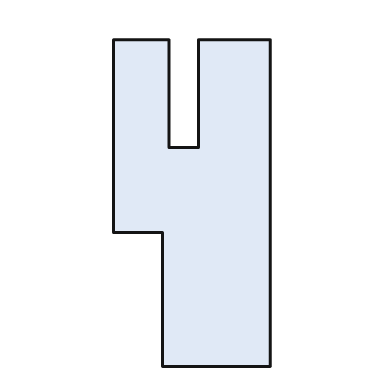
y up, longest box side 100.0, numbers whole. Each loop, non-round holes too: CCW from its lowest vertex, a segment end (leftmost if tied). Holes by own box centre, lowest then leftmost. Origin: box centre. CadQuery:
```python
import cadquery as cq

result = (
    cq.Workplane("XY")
    .moveTo(-9.0, -50.0)
    .lineTo(24.0, -50.0)
    .lineTo(24.0, 50.0)
    .lineTo(2.0, 50.0)
    .lineTo(2.0, 17.0)
    .lineTo(-7.0, 17.0)
    .lineTo(-7.0, 50.0)
    .lineTo(-24.0, 50.0)
    .lineTo(-24.0, -9.0)
    .lineTo(-9.0, -9.0)
    .close()
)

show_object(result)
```